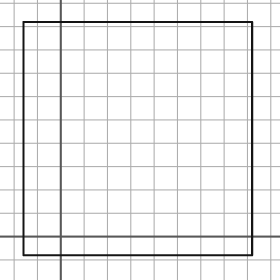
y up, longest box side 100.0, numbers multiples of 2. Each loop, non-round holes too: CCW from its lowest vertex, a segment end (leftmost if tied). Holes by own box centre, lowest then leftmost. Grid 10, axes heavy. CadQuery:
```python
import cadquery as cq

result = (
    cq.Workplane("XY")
    .moveTo(-16.0, -8.0)
    .lineTo(82.0, -8.0)
    .lineTo(82.0, 92.0)
    .lineTo(-16.0, 92.0)
    .close()
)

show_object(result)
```